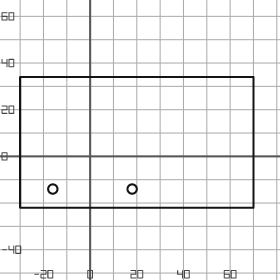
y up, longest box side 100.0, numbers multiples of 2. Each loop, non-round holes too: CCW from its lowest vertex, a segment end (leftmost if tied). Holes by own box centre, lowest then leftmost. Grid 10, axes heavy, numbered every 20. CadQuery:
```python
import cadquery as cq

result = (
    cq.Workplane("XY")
    .moveTo(-30.0, -22.0)
    .lineTo(70.0, -22.0)
    .lineTo(70.0, 34.0)
    .lineTo(-30.0, 34.0)
    .close()
    .moveTo(-16.0, -14.0)
    .circle(2.0)
    .moveTo(18.0, -14.0)
    .circle(2.0)
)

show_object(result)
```